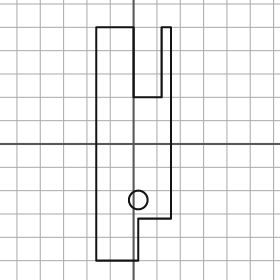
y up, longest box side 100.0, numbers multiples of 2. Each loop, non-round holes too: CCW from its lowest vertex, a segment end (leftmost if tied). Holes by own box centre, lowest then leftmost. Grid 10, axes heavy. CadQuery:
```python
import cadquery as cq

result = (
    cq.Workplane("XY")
    .moveTo(-16.0, -50.0)
    .lineTo(2.0, -50.0)
    .lineTo(2.0, -32.0)
    .lineTo(16.0, -32.0)
    .lineTo(16.0, 50.0)
    .lineTo(12.0, 50.0)
    .lineTo(12.0, 20.0)
    .lineTo(0.0, 20.0)
    .lineTo(0.0, 50.0)
    .lineTo(-16.0, 50.0)
    .close()
    .moveTo(2.0, -24.0)
    .circle(4.0)
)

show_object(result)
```